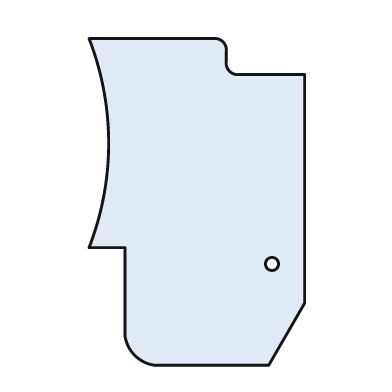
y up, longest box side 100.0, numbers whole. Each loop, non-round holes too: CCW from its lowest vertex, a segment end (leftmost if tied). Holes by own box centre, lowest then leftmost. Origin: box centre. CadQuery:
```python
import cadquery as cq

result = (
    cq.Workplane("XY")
    .moveTo(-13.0, -50.0)
    .lineTo(22.0, -50.0)
    .lineTo(33.0, -31.0)
    .lineTo(33.0, 39.0)
    .lineTo(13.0, 39.0)
    .threePointArc((10.0, 40.0), (9.0, 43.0))
    .lineTo(9.0, 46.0)
    .threePointArc((8.0, 49.0), (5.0, 50.0))
    .lineTo(-33.0, 50.0)
    .threePointArc((-27.0, 18.0), (-33.0, -14.0))
    .lineTo(-22.0, -14.0)
    .lineTo(-22.0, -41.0)
    .threePointArc((-19.0, -47.0), (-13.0, -50.0))
    .close()
    .moveTo(23.0, -19.0)
    .circle(2.0)
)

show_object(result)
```